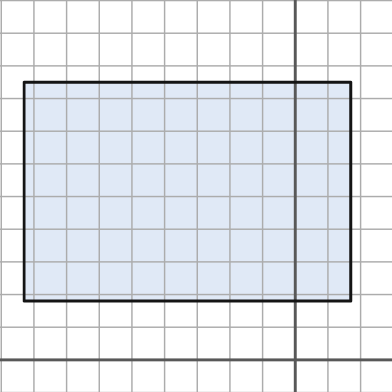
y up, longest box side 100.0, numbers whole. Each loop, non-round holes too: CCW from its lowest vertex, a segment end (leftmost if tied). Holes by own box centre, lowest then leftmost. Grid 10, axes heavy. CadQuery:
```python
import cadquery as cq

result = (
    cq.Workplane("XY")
    .moveTo(-83.0, 18.0)
    .lineTo(17.0, 18.0)
    .lineTo(17.0, 85.0)
    .lineTo(-83.0, 85.0)
    .close()
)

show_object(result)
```